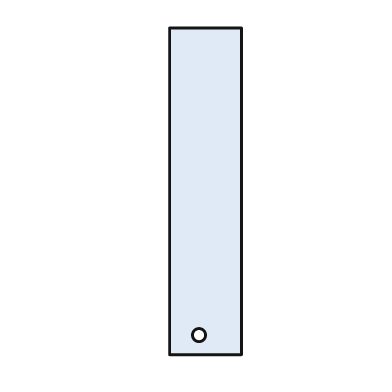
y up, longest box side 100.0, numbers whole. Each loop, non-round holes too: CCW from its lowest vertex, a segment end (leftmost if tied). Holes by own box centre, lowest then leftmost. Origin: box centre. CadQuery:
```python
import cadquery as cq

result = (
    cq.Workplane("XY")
    .moveTo(-11.0, -50.0)
    .lineTo(11.0, -50.0)
    .lineTo(11.0, 50.0)
    .lineTo(-11.0, 50.0)
    .close()
    .moveTo(-2.0, -44.0)
    .circle(2.0)
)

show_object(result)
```